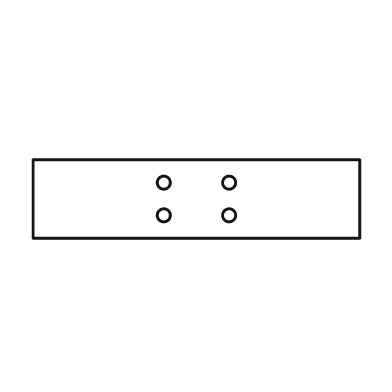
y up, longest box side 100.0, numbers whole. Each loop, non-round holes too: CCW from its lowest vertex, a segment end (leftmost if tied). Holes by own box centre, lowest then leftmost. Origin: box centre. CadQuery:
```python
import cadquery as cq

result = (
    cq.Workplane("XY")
    .moveTo(-50.0, -12.0)
    .lineTo(50.0, -12.0)
    .lineTo(50.0, 12.0)
    .lineTo(-50.0, 12.0)
    .close()
    .moveTo(-10.0, -5.0)
    .circle(2.0)
    .moveTo(10.0, -5.0)
    .circle(2.0)
    .moveTo(-10.0, 5.0)
    .circle(2.0)
    .moveTo(10.0, 5.0)
    .circle(2.0)
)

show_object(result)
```